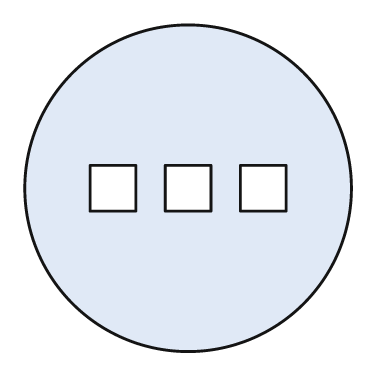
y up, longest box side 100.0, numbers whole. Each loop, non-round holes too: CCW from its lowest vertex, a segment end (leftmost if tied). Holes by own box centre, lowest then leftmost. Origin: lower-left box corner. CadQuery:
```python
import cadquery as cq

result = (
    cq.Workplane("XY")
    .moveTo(50.0, 50.0)
    .circle(50.0)
    .moveTo(20.0, 43.0)
    .lineTo(34.0, 43.0)
    .lineTo(34.0, 57.0)
    .lineTo(20.0, 57.0)
    .close()
    .moveTo(43.0, 43.0)
    .lineTo(57.0, 43.0)
    .lineTo(57.0, 57.0)
    .lineTo(43.0, 57.0)
    .close()
    .moveTo(66.0, 43.0)
    .lineTo(80.0, 43.0)
    .lineTo(80.0, 57.0)
    .lineTo(66.0, 57.0)
    .close()
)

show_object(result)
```